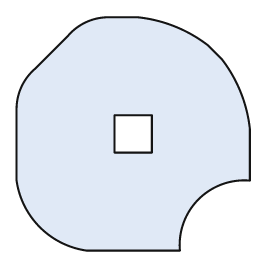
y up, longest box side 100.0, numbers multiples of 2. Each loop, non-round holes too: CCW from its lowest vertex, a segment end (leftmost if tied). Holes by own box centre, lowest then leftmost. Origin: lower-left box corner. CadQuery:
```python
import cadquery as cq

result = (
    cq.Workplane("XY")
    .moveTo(30.0, 0.0)
    .lineTo(70.0, 0.0)
    .threePointArc((78.0, 22.0), (100.0, 30.0))
    .lineTo(100.0, 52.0)
    .threePointArc((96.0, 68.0), (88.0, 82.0))
    .lineTo(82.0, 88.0)
    .threePointArc((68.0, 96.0), (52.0, 100.0))
    .lineTo(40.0, 100.0)
    .threePointArc((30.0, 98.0), (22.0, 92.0))
    .lineTo(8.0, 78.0)
    .threePointArc((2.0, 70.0), (0.0, 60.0))
    .lineTo(0.0, 30.0)
    .threePointArc((10.0, 10.0), (30.0, 0.0))
    .close()
    .moveTo(42.0, 42.0)
    .lineTo(58.0, 42.0)
    .lineTo(58.0, 58.0)
    .lineTo(42.0, 58.0)
    .close()
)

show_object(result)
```